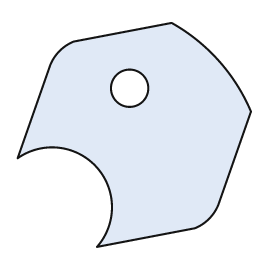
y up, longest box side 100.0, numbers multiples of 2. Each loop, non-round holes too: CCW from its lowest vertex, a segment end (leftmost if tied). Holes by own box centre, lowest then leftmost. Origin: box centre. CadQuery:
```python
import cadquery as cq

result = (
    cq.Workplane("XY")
    .moveTo(-16.0, -48.0)
    .lineTo(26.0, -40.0)
    .threePointArc((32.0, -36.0), (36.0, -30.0))
    .lineTo(50.0, 10.0)
    .threePointArc((36.0, 32.0), (16.0, 48.0))
    .lineTo(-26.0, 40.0)
    .threePointArc((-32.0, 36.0), (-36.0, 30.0))
    .lineTo(-50.0, -10.0)
    .threePointArc((-16.0, -14.0), (-16.0, -48.0))
    .close()
    .moveTo(-2.0, 20.0)
    .circle(8.0)
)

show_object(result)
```